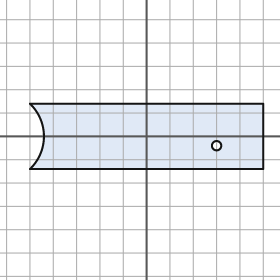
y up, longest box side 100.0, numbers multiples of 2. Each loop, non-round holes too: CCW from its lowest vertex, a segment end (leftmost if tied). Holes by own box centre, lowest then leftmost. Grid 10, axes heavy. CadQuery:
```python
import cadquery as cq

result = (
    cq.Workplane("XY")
    .moveTo(-50.0, -14.0)
    .lineTo(50.0, -14.0)
    .lineTo(50.0, 14.0)
    .lineTo(-50.0, 14.0)
    .threePointArc((-44.0, 0.0), (-50.0, -14.0))
    .close()
    .moveTo(30.0, -4.0)
    .circle(2.0)
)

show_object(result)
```